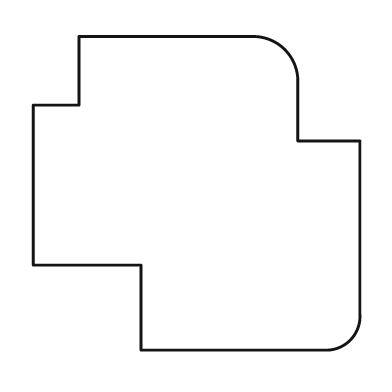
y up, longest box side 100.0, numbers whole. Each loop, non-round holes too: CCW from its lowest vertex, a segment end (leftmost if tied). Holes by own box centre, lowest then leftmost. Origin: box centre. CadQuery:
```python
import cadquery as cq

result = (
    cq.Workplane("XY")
    .moveTo(-17.0, -48.0)
    .lineTo(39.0, -48.0)
    .threePointArc((47.0, -45.0), (50.0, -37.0))
    .lineTo(50.0, 16.0)
    .lineTo(31.0, 16.0)
    .lineTo(31.0, 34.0)
    .threePointArc((27.0, 44.0), (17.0, 48.0))
    .lineTo(-36.0, 48.0)
    .lineTo(-36.0, 27.0)
    .lineTo(-50.0, 27.0)
    .lineTo(-50.0, -22.0)
    .lineTo(-17.0, -22.0)
    .close()
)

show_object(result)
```